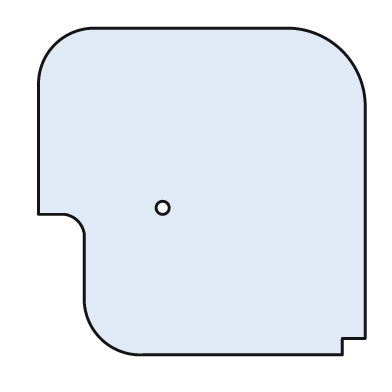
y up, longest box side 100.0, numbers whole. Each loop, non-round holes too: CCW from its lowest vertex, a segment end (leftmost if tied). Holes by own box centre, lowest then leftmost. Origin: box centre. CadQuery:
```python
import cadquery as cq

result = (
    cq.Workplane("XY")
    .moveTo(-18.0, -50.0)
    .lineTo(43.0, -50.0)
    .lineTo(43.0, -45.0)
    .lineTo(50.0, -45.0)
    .lineTo(50.0, 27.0)
    .threePointArc((43.0, 43.0), (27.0, 50.0))
    .lineTo(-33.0, 50.0)
    .threePointArc((-45.0, 45.0), (-50.0, 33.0))
    .lineTo(-50.0, -7.0)
    .lineTo(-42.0, -7.0)
    .threePointArc((-38.0, -9.0), (-36.0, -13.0))
    .lineTo(-36.0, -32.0)
    .threePointArc((-31.0, -45.0), (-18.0, -50.0))
    .close()
    .moveTo(-12.0, -5.0)
    .circle(2.0)
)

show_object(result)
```